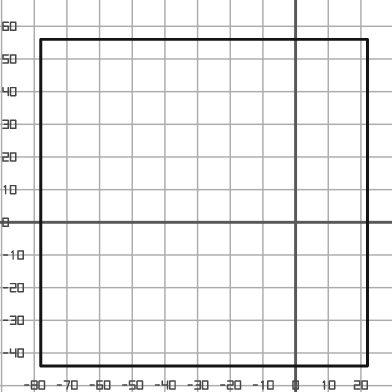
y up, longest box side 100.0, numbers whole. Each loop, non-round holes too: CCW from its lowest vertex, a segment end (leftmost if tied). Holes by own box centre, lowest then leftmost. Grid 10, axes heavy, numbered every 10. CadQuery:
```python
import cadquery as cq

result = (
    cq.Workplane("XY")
    .moveTo(-78.0, -44.0)
    .lineTo(22.0, -44.0)
    .lineTo(22.0, 56.0)
    .lineTo(-78.0, 56.0)
    .close()
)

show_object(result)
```